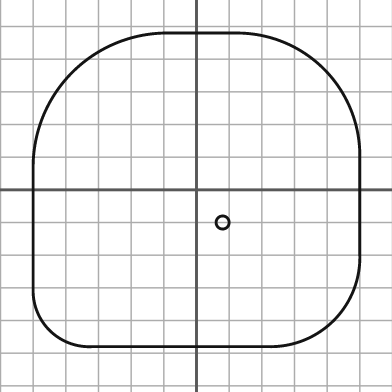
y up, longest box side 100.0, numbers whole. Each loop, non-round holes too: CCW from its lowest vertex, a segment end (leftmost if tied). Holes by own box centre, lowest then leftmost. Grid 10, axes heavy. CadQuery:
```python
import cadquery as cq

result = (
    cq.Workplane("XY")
    .moveTo(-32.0, -48.0)
    .lineTo(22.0, -48.0)
    .threePointArc((42.0, -40.0), (50.0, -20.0))
    .lineTo(50.0, 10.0)
    .threePointArc((39.0, 37.0), (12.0, 48.0))
    .lineTo(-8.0, 48.0)
    .threePointArc((-38.0, 36.0), (-50.0, 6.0))
    .lineTo(-50.0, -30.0)
    .threePointArc((-45.0, -43.0), (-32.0, -48.0))
    .close()
    .moveTo(8.0, -10.0)
    .circle(2.0)
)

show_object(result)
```